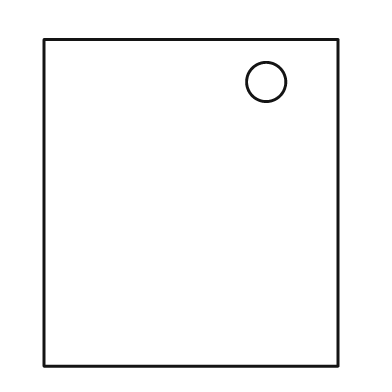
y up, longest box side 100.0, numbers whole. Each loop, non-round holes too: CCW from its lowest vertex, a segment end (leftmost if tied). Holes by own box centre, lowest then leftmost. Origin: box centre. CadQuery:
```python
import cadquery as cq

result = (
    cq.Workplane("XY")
    .moveTo(-45.0, -50.0)
    .lineTo(45.0, -50.0)
    .lineTo(45.0, 50.0)
    .lineTo(-45.0, 50.0)
    .close()
    .moveTo(23.0, 37.0)
    .circle(6.0)
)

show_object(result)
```